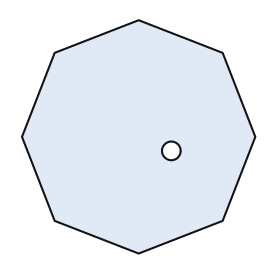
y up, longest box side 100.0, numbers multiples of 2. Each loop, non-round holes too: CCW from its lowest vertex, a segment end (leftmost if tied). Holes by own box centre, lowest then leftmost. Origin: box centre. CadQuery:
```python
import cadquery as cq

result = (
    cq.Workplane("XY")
    .moveTo(0.0, -50.0)
    .lineTo(36.0, -36.0)
    .lineTo(50.0, 0.0)
    .lineTo(36.0, 36.0)
    .lineTo(0.0, 50.0)
    .lineTo(-36.0, 36.0)
    .lineTo(-50.0, 0.0)
    .lineTo(-36.0, -36.0)
    .close()
    .moveTo(14.0, -6.0)
    .circle(4.0)
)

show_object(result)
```